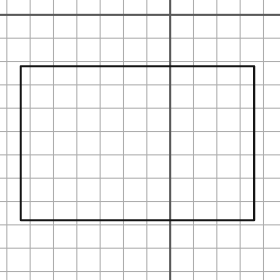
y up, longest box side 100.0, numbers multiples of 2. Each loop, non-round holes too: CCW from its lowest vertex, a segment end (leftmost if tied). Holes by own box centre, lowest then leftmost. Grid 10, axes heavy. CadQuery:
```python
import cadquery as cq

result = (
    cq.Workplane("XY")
    .moveTo(-64.0, -88.0)
    .lineTo(36.0, -88.0)
    .lineTo(36.0, -22.0)
    .lineTo(-64.0, -22.0)
    .close()
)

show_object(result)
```